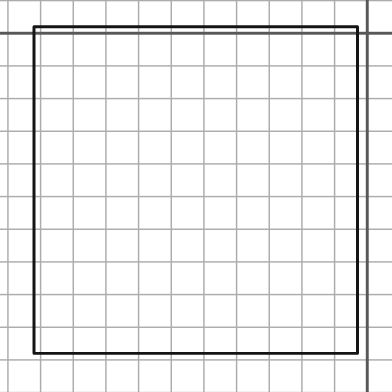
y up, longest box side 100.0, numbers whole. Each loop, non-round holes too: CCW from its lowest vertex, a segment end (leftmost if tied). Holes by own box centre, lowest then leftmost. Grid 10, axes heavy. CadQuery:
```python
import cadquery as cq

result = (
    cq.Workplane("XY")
    .moveTo(-102.0, -98.0)
    .lineTo(-3.0, -98.0)
    .lineTo(-3.0, 2.0)
    .lineTo(-102.0, 2.0)
    .close()
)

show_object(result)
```